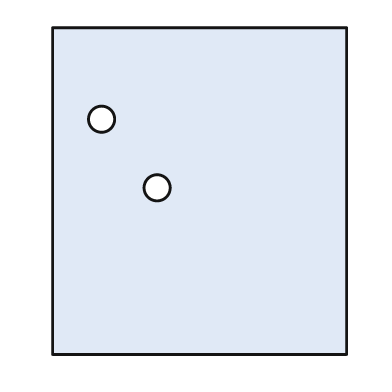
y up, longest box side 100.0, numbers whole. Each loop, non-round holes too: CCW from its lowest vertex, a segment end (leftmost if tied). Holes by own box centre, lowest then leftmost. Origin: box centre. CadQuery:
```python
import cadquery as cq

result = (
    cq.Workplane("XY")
    .moveTo(-45.0, -50.0)
    .lineTo(45.0, -50.0)
    .lineTo(45.0, 50.0)
    .lineTo(-45.0, 50.0)
    .close()
    .moveTo(-13.0, 1.0)
    .circle(4.0)
    .moveTo(-30.0, 22.0)
    .circle(4.0)
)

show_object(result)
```